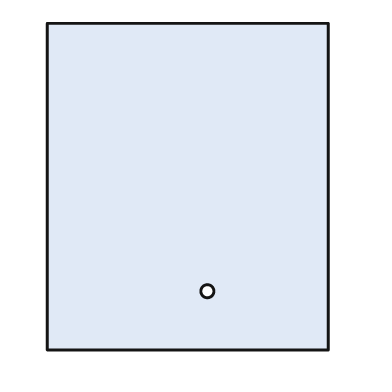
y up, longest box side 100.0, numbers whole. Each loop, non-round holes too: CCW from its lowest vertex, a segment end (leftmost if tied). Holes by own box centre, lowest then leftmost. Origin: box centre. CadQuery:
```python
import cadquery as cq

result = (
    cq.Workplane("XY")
    .moveTo(-43.0, -50.0)
    .lineTo(43.0, -50.0)
    .lineTo(43.0, 50.0)
    .lineTo(-43.0, 50.0)
    .close()
    .moveTo(6.0, -32.0)
    .circle(2.0)
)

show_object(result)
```